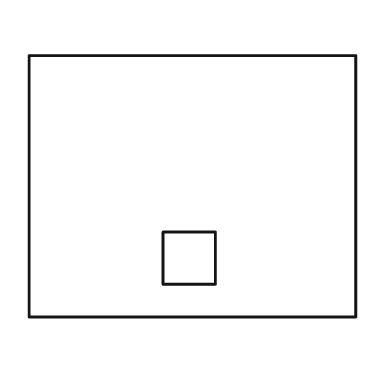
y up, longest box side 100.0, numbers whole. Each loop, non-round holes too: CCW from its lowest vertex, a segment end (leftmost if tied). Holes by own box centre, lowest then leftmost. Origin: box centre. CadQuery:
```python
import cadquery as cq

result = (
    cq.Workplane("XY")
    .moveTo(-50.0, -40.0)
    .lineTo(50.0, -40.0)
    .lineTo(50.0, 40.0)
    .lineTo(-50.0, 40.0)
    .close()
    .moveTo(-9.0, -30.0)
    .lineTo(7.0, -30.0)
    .lineTo(7.0, -14.0)
    .lineTo(-9.0, -14.0)
    .close()
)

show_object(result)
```